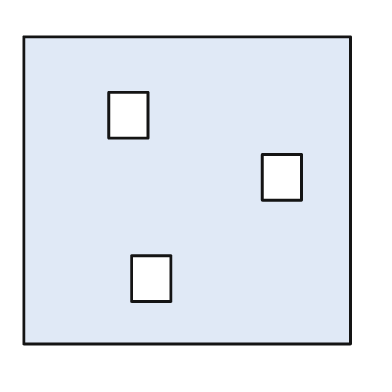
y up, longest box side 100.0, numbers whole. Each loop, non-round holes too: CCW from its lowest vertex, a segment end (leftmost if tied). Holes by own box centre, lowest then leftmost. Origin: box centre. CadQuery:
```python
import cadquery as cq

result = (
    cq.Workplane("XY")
    .moveTo(-50.0, -47.0)
    .lineTo(50.0, -47.0)
    .lineTo(50.0, 47.0)
    .lineTo(-50.0, 47.0)
    .close()
    .moveTo(-17.0, -34.0)
    .lineTo(-5.0, -34.0)
    .lineTo(-5.0, -20.0)
    .lineTo(-17.0, -20.0)
    .close()
    .moveTo(23.0, -3.0)
    .lineTo(35.0, -3.0)
    .lineTo(35.0, 11.0)
    .lineTo(23.0, 11.0)
    .close()
    .moveTo(-24.0, 16.0)
    .lineTo(-12.0, 16.0)
    .lineTo(-12.0, 30.0)
    .lineTo(-24.0, 30.0)
    .close()
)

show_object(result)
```